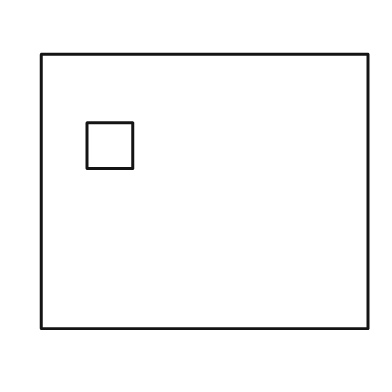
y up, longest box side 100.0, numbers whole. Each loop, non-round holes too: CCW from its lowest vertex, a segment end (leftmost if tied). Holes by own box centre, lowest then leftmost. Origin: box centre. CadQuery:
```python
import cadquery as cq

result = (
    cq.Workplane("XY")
    .moveTo(-50.0, -42.0)
    .lineTo(50.0, -42.0)
    .lineTo(50.0, 42.0)
    .lineTo(-50.0, 42.0)
    .close()
    .moveTo(-36.0, 7.0)
    .lineTo(-22.0, 7.0)
    .lineTo(-22.0, 21.0)
    .lineTo(-36.0, 21.0)
    .close()
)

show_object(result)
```